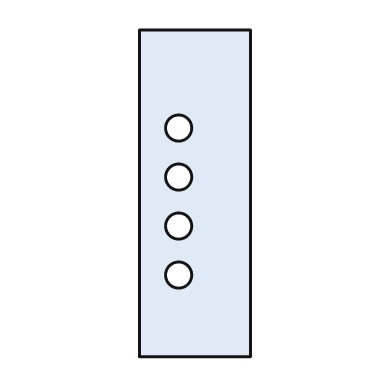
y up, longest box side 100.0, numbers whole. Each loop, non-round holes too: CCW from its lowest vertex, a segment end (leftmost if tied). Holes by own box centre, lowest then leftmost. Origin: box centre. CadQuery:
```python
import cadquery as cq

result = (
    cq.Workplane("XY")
    .moveTo(-17.0, -50.0)
    .lineTo(17.0, -50.0)
    .lineTo(17.0, 50.0)
    .lineTo(-17.0, 50.0)
    .close()
    .moveTo(-5.0, -25.0)
    .circle(4.0)
    .moveTo(-5.0, -10.0)
    .circle(4.0)
    .moveTo(-5.0, 5.0)
    .circle(4.0)
    .moveTo(-5.0, 20.0)
    .circle(4.0)
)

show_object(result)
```